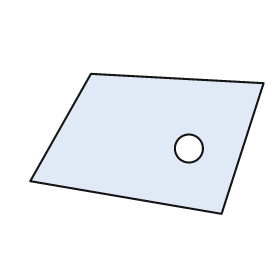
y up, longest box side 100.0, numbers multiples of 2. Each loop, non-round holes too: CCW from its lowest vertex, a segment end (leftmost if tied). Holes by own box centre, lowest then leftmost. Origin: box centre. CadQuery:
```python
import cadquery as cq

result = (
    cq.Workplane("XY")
    .moveTo(32.0, -30.0)
    .lineTo(50.0, 26.0)
    .lineTo(-24.0, 30.0)
    .lineTo(-50.0, -16.0)
    .close()
    .moveTo(18.0, -2.0)
    .circle(6.0)
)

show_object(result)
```